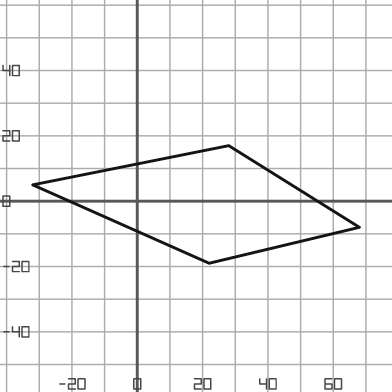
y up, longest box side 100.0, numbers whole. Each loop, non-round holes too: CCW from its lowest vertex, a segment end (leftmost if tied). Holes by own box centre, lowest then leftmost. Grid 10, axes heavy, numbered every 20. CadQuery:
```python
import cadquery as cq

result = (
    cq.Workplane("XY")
    .moveTo(22.0, -19.0)
    .lineTo(68.0, -8.0)
    .lineTo(28.0, 17.0)
    .lineTo(-32.0, 5.0)
    .close()
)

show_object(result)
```